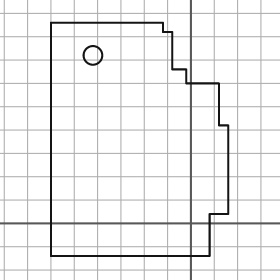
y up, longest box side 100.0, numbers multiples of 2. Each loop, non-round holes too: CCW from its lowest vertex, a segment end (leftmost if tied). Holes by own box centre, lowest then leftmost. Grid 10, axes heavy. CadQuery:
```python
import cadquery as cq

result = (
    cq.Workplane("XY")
    .moveTo(-60.0, -14.0)
    .lineTo(8.0, -14.0)
    .lineTo(8.0, 4.0)
    .lineTo(16.0, 4.0)
    .lineTo(16.0, 42.0)
    .lineTo(12.0, 42.0)
    .lineTo(12.0, 60.0)
    .lineTo(-2.0, 60.0)
    .lineTo(-2.0, 66.0)
    .lineTo(-8.0, 66.0)
    .lineTo(-8.0, 82.0)
    .lineTo(-12.0, 82.0)
    .lineTo(-12.0, 86.0)
    .lineTo(-60.0, 86.0)
    .close()
    .moveTo(-42.0, 72.0)
    .circle(4.0)
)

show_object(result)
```